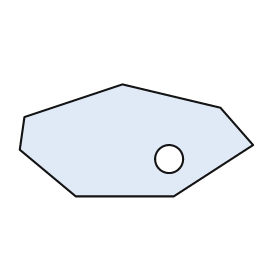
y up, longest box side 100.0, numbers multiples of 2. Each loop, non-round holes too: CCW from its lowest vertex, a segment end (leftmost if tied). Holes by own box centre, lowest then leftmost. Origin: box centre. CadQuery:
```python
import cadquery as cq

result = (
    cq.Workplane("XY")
    .moveTo(-26.0, -24.0)
    .lineTo(16.0, -24.0)
    .lineTo(50.0, -2.0)
    .lineTo(36.0, 14.0)
    .lineTo(-6.0, 24.0)
    .lineTo(-48.0, 10.0)
    .lineTo(-50.0, -4.0)
    .close()
    .moveTo(14.0, -8.0)
    .circle(6.0)
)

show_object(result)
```